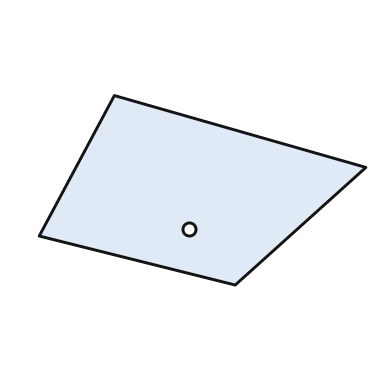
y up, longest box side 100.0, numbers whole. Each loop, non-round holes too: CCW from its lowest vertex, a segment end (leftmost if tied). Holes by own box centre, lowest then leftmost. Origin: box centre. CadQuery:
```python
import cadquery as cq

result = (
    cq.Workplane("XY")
    .moveTo(10.0, -29.0)
    .lineTo(50.0, 7.0)
    .lineTo(-27.0, 29.0)
    .lineTo(-50.0, -14.0)
    .close()
    .moveTo(-4.0, -12.0)
    .circle(2.0)
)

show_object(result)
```